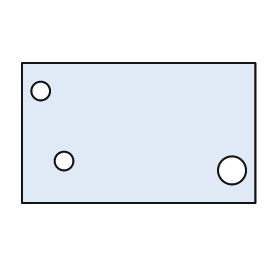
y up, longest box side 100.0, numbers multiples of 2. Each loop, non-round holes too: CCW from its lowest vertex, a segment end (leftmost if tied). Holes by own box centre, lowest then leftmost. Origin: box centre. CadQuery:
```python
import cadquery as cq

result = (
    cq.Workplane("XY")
    .moveTo(-50.0, -30.0)
    .lineTo(50.0, -30.0)
    .lineTo(50.0, 30.0)
    .lineTo(-50.0, 30.0)
    .close()
    .moveTo(40.0, -16.0)
    .circle(6.0)
    .moveTo(-32.0, -12.0)
    .circle(4.0)
    .moveTo(-42.0, 18.0)
    .circle(4.0)
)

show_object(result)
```